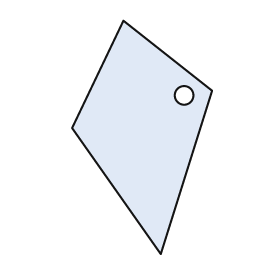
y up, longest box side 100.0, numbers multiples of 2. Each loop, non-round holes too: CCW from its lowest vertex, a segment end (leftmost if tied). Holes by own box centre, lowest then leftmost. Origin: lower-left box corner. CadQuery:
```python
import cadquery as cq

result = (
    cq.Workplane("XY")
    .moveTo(38.0, 0.0)
    .lineTo(60.0, 70.0)
    .lineTo(22.0, 100.0)
    .lineTo(0.0, 54.0)
    .close()
    .moveTo(48.0, 68.0)
    .circle(4.0)
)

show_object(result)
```